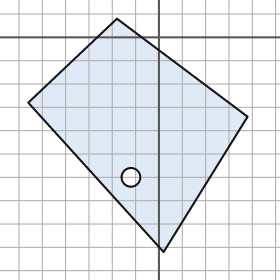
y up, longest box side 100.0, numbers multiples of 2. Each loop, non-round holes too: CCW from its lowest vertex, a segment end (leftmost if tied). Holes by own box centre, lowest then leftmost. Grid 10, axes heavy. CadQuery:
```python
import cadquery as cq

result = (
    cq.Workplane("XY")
    .moveTo(2.0, -92.0)
    .lineTo(38.0, -34.0)
    .lineTo(-18.0, 8.0)
    .lineTo(-56.0, -28.0)
    .close()
    .moveTo(-12.0, -60.0)
    .circle(4.0)
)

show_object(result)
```